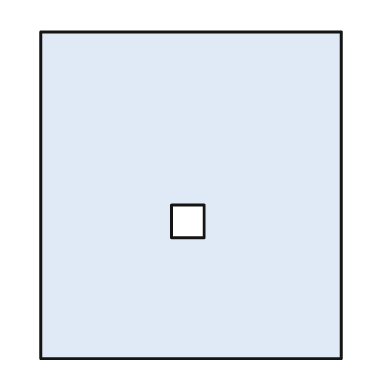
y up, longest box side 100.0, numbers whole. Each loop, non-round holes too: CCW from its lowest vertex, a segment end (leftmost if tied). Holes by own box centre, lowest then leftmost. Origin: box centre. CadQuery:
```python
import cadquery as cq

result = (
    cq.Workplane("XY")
    .moveTo(-46.0, -50.0)
    .lineTo(46.0, -50.0)
    .lineTo(46.0, 50.0)
    .lineTo(-46.0, 50.0)
    .close()
    .moveTo(-6.0, -13.0)
    .lineTo(4.0, -13.0)
    .lineTo(4.0, -3.0)
    .lineTo(-6.0, -3.0)
    .close()
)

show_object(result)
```